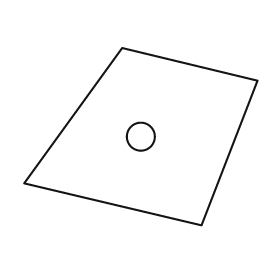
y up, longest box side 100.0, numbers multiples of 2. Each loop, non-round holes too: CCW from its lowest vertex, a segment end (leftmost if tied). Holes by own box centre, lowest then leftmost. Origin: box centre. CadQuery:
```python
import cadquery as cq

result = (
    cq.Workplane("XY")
    .moveTo(26.0, -38.0)
    .lineTo(50.0, 24.0)
    .lineTo(-8.0, 38.0)
    .lineTo(-50.0, -20.0)
    .close()
    .moveTo(0.0, 0.0)
    .circle(6.0)
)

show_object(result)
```